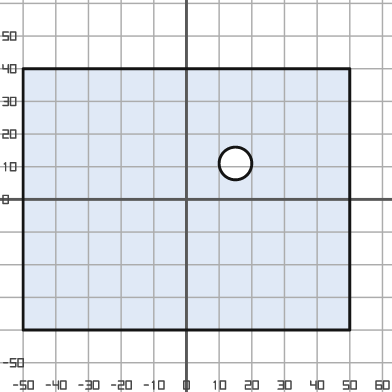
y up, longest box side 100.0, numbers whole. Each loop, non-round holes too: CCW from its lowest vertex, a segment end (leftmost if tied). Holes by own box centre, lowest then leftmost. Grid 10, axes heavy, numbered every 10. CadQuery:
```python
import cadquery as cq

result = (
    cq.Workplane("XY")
    .moveTo(-50.0, -40.0)
    .lineTo(50.0, -40.0)
    .lineTo(50.0, 40.0)
    .lineTo(-50.0, 40.0)
    .close()
    .moveTo(15.0, 11.0)
    .circle(5.0)
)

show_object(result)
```